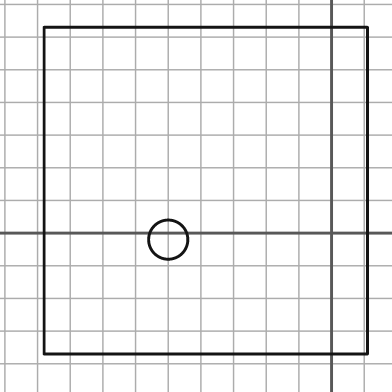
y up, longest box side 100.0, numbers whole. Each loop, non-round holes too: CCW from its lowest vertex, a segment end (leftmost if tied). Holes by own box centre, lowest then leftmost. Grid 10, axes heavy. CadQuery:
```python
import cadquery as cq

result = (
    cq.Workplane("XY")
    .moveTo(-88.0, -37.0)
    .lineTo(11.0, -37.0)
    .lineTo(11.0, 63.0)
    .lineTo(-88.0, 63.0)
    .close()
    .moveTo(-50.0, -2.0)
    .circle(6.0)
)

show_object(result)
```